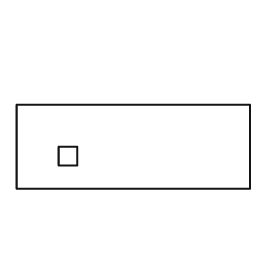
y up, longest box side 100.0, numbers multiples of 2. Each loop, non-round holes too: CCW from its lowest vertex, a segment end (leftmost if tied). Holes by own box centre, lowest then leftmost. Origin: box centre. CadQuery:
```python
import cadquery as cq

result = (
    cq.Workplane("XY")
    .moveTo(-50.0, -18.0)
    .lineTo(50.0, -18.0)
    .lineTo(50.0, 18.0)
    .lineTo(-50.0, 18.0)
    .close()
    .moveTo(-32.0, -8.0)
    .lineTo(-24.0, -8.0)
    .lineTo(-24.0, 0.0)
    .lineTo(-32.0, 0.0)
    .close()
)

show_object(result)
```